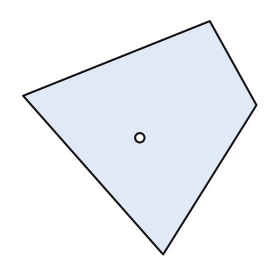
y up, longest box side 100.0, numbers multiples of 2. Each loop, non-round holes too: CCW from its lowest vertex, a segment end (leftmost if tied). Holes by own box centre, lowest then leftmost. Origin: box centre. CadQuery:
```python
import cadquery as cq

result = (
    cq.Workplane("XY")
    .moveTo(10.0, -50.0)
    .lineTo(50.0, 14.0)
    .lineTo(30.0, 50.0)
    .lineTo(-50.0, 18.0)
    .close()
    .moveTo(0.0, 0.0)
    .circle(2.0)
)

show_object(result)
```